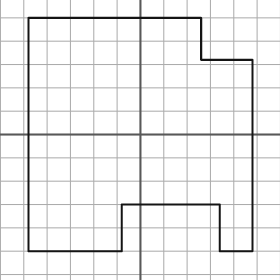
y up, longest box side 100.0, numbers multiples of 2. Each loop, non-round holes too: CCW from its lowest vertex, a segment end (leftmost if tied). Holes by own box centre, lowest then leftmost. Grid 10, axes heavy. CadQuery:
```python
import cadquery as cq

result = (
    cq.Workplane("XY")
    .moveTo(-48.0, -50.0)
    .lineTo(-8.0, -50.0)
    .lineTo(-8.0, -30.0)
    .lineTo(34.0, -30.0)
    .lineTo(34.0, -50.0)
    .lineTo(48.0, -50.0)
    .lineTo(48.0, 32.0)
    .lineTo(26.0, 32.0)
    .lineTo(26.0, 50.0)
    .lineTo(-48.0, 50.0)
    .close()
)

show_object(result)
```